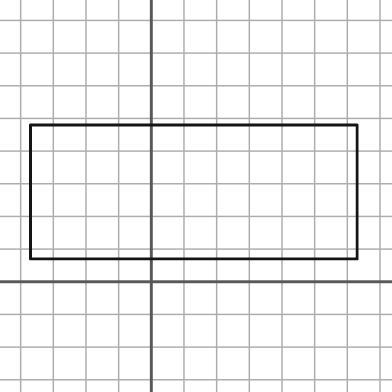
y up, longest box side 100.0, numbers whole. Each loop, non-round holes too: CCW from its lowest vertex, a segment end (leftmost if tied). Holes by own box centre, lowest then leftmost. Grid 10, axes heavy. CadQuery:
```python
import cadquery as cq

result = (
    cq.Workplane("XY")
    .moveTo(-37.0, 7.0)
    .lineTo(63.0, 7.0)
    .lineTo(63.0, 48.0)
    .lineTo(-37.0, 48.0)
    .close()
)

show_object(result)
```